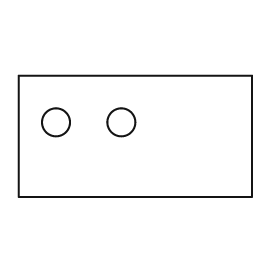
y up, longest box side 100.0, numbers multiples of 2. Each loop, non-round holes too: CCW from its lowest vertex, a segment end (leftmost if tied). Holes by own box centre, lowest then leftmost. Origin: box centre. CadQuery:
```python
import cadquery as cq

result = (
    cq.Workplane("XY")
    .moveTo(-50.0, -26.0)
    .lineTo(50.0, -26.0)
    .lineTo(50.0, 26.0)
    .lineTo(-50.0, 26.0)
    .close()
    .moveTo(-34.0, 6.0)
    .circle(6.0)
    .moveTo(-6.0, 6.0)
    .circle(6.0)
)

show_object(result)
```